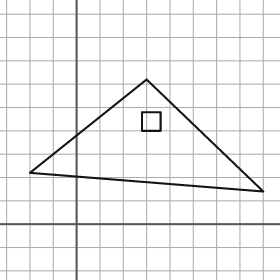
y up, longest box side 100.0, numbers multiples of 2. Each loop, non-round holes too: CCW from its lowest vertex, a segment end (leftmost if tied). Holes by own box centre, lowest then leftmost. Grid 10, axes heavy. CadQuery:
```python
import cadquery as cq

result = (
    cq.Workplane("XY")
    .moveTo(80.0, 14.0)
    .lineTo(30.0, 62.0)
    .lineTo(-20.0, 22.0)
    .close()
    .moveTo(28.0, 40.0)
    .lineTo(36.0, 40.0)
    .lineTo(36.0, 48.0)
    .lineTo(28.0, 48.0)
    .close()
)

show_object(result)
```